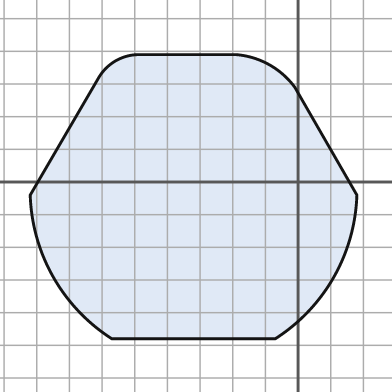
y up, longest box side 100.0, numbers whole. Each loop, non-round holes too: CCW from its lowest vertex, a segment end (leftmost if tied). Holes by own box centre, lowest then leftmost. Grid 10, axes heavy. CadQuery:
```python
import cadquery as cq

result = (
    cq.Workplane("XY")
    .moveTo(-57.0, -48.0)
    .lineTo(-7.0, -48.0)
    .threePointArc((11.0, -29.0), (18.0, -4.0))
    .lineTo(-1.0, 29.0)
    .threePointArc((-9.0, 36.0), (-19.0, 39.0))
    .lineTo(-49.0, 39.0)
    .threePointArc((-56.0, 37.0), (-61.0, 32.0))
    .lineTo(-82.0, -4.0)
    .threePointArc((-75.0, -29.0), (-57.0, -48.0))
    .close()
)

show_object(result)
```